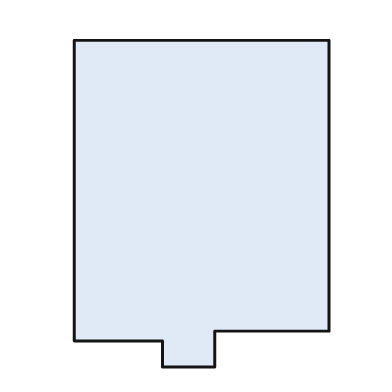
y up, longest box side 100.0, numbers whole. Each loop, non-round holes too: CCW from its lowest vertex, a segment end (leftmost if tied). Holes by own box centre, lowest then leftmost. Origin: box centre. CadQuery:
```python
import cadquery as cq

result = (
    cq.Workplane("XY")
    .moveTo(-12.0, -50.0)
    .lineTo(4.0, -50.0)
    .lineTo(4.0, -39.0)
    .lineTo(39.0, -39.0)
    .lineTo(39.0, 50.0)
    .lineTo(-39.0, 50.0)
    .lineTo(-39.0, -42.0)
    .lineTo(-12.0, -42.0)
    .close()
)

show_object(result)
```